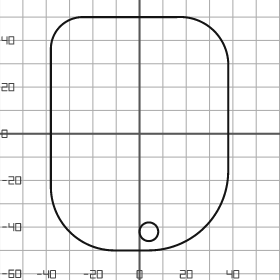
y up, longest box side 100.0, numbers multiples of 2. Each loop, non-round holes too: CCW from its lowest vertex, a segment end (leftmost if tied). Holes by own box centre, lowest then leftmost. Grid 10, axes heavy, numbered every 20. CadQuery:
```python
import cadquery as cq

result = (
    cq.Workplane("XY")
    .moveTo(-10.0, -50.0)
    .lineTo(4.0, -50.0)
    .threePointArc((28.0, -40.0), (38.0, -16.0))
    .lineTo(38.0, 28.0)
    .threePointArc((32.0, 44.0), (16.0, 50.0))
    .lineTo(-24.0, 50.0)
    .threePointArc((-34.0, 46.0), (-38.0, 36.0))
    .lineTo(-38.0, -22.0)
    .threePointArc((-30.0, -42.0), (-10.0, -50.0))
    .close()
    .moveTo(4.0, -42.0)
    .circle(4.0)
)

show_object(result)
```